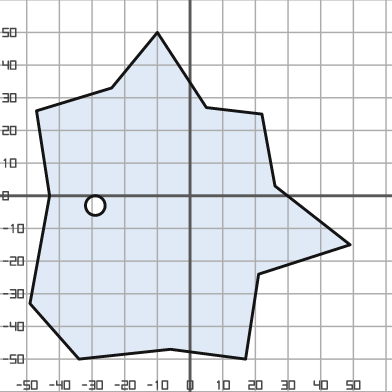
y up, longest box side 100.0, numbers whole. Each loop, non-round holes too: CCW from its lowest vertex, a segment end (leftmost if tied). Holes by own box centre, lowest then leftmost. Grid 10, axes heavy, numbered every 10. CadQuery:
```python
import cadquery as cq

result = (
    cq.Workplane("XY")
    .moveTo(-34.0, -50.0)
    .lineTo(-6.0, -47.0)
    .lineTo(17.0, -50.0)
    .lineTo(21.0, -24.0)
    .lineTo(49.0, -15.0)
    .lineTo(26.0, 3.0)
    .lineTo(22.0, 25.0)
    .lineTo(5.0, 27.0)
    .lineTo(-10.0, 50.0)
    .lineTo(-24.0, 33.0)
    .lineTo(-47.0, 26.0)
    .lineTo(-43.0, 0.0)
    .lineTo(-49.0, -33.0)
    .close()
    .moveTo(-29.0, -3.0)
    .circle(3.0)
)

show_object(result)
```